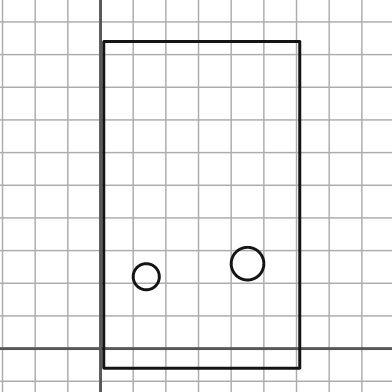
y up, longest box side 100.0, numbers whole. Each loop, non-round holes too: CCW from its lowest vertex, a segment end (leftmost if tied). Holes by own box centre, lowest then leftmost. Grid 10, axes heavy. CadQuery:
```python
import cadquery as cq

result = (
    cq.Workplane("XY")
    .moveTo(1.0, -6.0)
    .lineTo(61.0, -6.0)
    .lineTo(61.0, 94.0)
    .lineTo(1.0, 94.0)
    .close()
    .moveTo(14.0, 22.0)
    .circle(4.0)
    .moveTo(45.0, 26.0)
    .circle(5.0)
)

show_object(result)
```